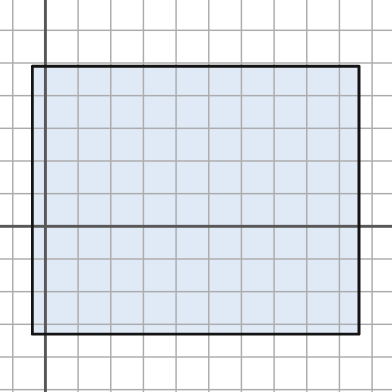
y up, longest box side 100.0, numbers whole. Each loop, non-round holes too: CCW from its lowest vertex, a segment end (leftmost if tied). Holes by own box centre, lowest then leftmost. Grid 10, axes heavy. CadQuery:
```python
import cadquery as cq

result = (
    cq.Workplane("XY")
    .moveTo(-4.0, -33.0)
    .lineTo(96.0, -33.0)
    .lineTo(96.0, 49.0)
    .lineTo(-4.0, 49.0)
    .close()
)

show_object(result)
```